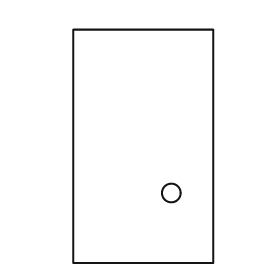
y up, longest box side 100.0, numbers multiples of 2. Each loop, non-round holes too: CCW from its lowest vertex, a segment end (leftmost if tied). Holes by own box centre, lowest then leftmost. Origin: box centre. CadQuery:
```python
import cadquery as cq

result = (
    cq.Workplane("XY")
    .moveTo(-30.0, -50.0)
    .lineTo(30.0, -50.0)
    .lineTo(30.0, 50.0)
    .lineTo(-30.0, 50.0)
    .close()
    .moveTo(12.0, -20.0)
    .circle(4.0)
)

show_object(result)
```